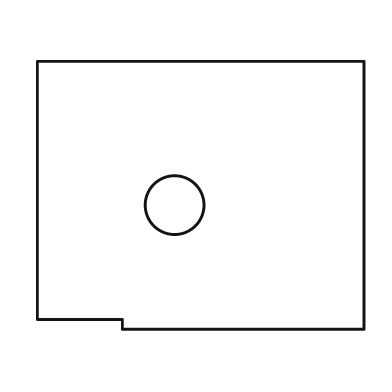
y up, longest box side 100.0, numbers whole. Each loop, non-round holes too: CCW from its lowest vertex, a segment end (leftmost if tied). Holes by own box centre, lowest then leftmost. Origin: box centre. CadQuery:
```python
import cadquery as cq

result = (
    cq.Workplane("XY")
    .moveTo(-24.0, -41.0)
    .lineTo(50.0, -41.0)
    .lineTo(50.0, 41.0)
    .lineTo(-50.0, 41.0)
    .lineTo(-50.0, -38.0)
    .lineTo(-24.0, -38.0)
    .close()
    .moveTo(-8.0, -3.0)
    .circle(9.0)
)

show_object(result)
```